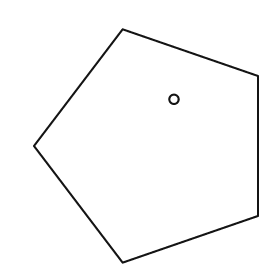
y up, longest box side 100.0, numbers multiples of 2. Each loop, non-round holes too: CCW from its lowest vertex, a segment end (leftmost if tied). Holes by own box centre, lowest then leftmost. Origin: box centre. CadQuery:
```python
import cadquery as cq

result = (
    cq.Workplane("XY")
    .moveTo(-10.0, -50.0)
    .lineTo(48.0, -30.0)
    .lineTo(48.0, 30.0)
    .lineTo(-10.0, 50.0)
    .lineTo(-48.0, 0.0)
    .close()
    .moveTo(12.0, 20.0)
    .circle(2.0)
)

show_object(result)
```